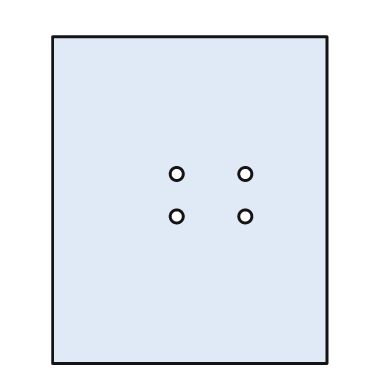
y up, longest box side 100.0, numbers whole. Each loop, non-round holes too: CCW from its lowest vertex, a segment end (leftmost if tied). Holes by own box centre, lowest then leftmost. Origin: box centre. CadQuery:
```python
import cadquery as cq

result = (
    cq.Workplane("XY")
    .moveTo(-42.0, -50.0)
    .lineTo(42.0, -50.0)
    .lineTo(42.0, 50.0)
    .lineTo(-42.0, 50.0)
    .close()
    .moveTo(-4.0, -5.0)
    .circle(2.0)
    .moveTo(17.0, -5.0)
    .circle(2.0)
    .moveTo(-4.0, 8.0)
    .circle(2.0)
    .moveTo(17.0, 8.0)
    .circle(2.0)
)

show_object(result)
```